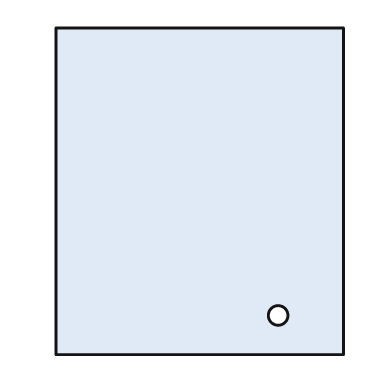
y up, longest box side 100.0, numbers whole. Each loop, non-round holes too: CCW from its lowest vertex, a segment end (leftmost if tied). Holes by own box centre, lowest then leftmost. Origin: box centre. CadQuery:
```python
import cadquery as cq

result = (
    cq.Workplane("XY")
    .moveTo(-44.0, -50.0)
    .lineTo(44.0, -50.0)
    .lineTo(44.0, 50.0)
    .lineTo(-44.0, 50.0)
    .close()
    .moveTo(24.0, -38.0)
    .circle(3.0)
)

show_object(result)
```